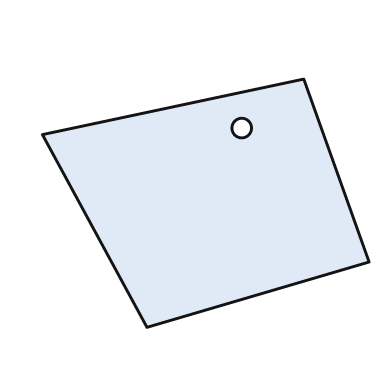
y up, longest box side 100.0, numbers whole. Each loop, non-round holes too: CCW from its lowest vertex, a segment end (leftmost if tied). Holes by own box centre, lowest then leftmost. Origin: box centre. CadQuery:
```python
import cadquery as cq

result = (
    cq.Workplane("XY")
    .moveTo(-18.0, -38.0)
    .lineTo(50.0, -18.0)
    .lineTo(30.0, 38.0)
    .lineTo(-50.0, 21.0)
    .close()
    .moveTo(11.0, 23.0)
    .circle(3.0)
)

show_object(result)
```